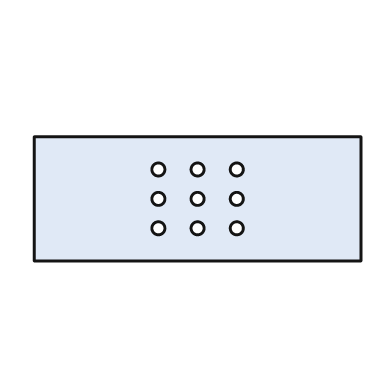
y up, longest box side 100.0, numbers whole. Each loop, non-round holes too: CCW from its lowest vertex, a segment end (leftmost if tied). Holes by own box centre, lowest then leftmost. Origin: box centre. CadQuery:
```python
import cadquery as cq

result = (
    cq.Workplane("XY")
    .moveTo(-50.0, -19.0)
    .lineTo(50.0, -19.0)
    .lineTo(50.0, 19.0)
    .lineTo(-50.0, 19.0)
    .close()
    .moveTo(-12.0, -9.0)
    .circle(2.0)
    .moveTo(0.0, -9.0)
    .circle(2.0)
    .moveTo(12.0, -9.0)
    .circle(2.0)
    .moveTo(-12.0, 0.0)
    .circle(2.0)
    .moveTo(0.0, 0.0)
    .circle(2.0)
    .moveTo(12.0, 0.0)
    .circle(2.0)
    .moveTo(-12.0, 9.0)
    .circle(2.0)
    .moveTo(0.0, 9.0)
    .circle(2.0)
    .moveTo(12.0, 9.0)
    .circle(2.0)
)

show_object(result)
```